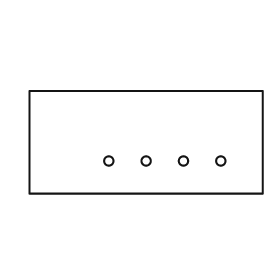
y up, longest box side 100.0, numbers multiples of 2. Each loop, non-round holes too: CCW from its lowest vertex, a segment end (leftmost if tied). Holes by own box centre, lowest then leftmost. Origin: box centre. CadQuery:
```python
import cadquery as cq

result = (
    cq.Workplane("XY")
    .moveTo(-50.0, -22.0)
    .lineTo(50.0, -22.0)
    .lineTo(50.0, 22.0)
    .lineTo(-50.0, 22.0)
    .close()
    .moveTo(-16.0, -8.0)
    .circle(2.0)
    .moveTo(0.0, -8.0)
    .circle(2.0)
    .moveTo(16.0, -8.0)
    .circle(2.0)
    .moveTo(32.0, -8.0)
    .circle(2.0)
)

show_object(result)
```